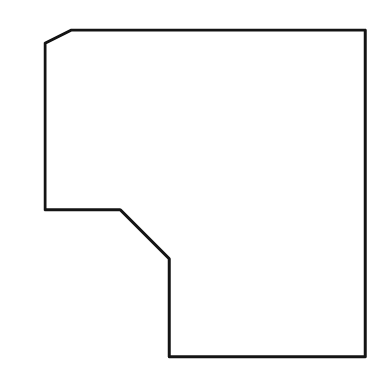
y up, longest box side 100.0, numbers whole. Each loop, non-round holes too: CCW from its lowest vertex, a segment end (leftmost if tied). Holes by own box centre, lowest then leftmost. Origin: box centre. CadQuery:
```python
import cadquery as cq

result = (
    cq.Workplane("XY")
    .moveTo(-11.0, -50.0)
    .lineTo(49.0, -50.0)
    .lineTo(49.0, 50.0)
    .lineTo(-41.0, 50.0)
    .lineTo(-49.0, 46.0)
    .lineTo(-49.0, -5.0)
    .lineTo(-26.0, -5.0)
    .lineTo(-11.0, -20.0)
    .close()
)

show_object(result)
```